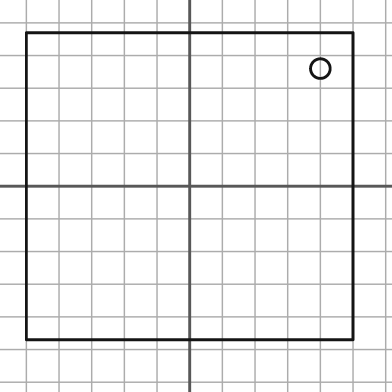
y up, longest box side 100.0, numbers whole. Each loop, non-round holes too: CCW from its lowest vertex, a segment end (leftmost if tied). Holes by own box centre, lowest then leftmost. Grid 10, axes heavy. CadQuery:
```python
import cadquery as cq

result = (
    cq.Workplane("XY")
    .moveTo(-50.0, -47.0)
    .lineTo(50.0, -47.0)
    .lineTo(50.0, 47.0)
    .lineTo(-50.0, 47.0)
    .close()
    .moveTo(40.0, 36.0)
    .circle(3.0)
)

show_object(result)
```